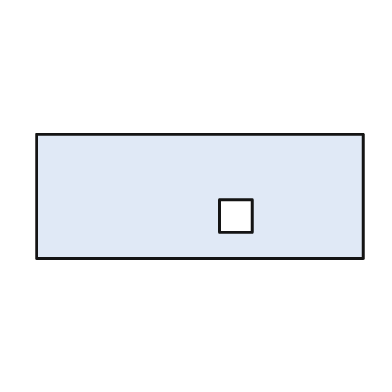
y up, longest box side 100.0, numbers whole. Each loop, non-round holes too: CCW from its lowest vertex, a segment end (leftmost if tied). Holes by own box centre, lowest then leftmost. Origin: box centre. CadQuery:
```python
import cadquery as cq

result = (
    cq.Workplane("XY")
    .moveTo(-50.0, -19.0)
    .lineTo(50.0, -19.0)
    .lineTo(50.0, 19.0)
    .lineTo(-50.0, 19.0)
    .close()
    .moveTo(6.0, -11.0)
    .lineTo(16.0, -11.0)
    .lineTo(16.0, -1.0)
    .lineTo(6.0, -1.0)
    .close()
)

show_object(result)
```